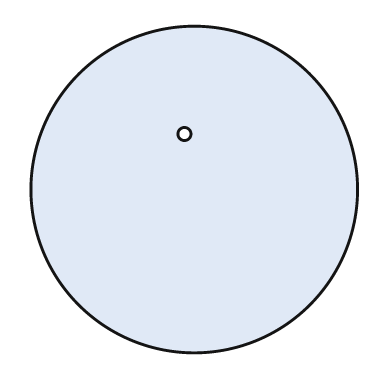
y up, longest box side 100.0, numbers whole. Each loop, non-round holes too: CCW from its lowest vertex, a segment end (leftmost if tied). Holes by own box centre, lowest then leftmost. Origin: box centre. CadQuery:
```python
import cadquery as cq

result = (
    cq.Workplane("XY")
    .moveTo(0.0, 0.0)
    .circle(50.0)
    .moveTo(-3.0, 17.0)
    .circle(2.0)
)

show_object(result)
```